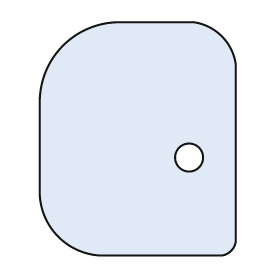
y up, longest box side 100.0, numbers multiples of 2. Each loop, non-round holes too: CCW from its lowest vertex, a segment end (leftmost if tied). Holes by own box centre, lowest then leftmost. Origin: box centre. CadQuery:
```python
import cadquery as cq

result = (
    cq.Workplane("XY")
    .moveTo(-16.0, -50.0)
    .lineTo(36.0, -50.0)
    .threePointArc((40.0, -48.0), (42.0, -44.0))
    .lineTo(42.0, 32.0)
    .threePointArc((36.0, 44.0), (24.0, 50.0))
    .lineTo(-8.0, 50.0)
    .threePointArc((-32.0, 40.0), (-42.0, 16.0))
    .lineTo(-42.0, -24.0)
    .threePointArc((-34.0, -42.0), (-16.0, -50.0))
    .close()
    .moveTo(22.0, -8.0)
    .circle(6.0)
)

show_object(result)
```